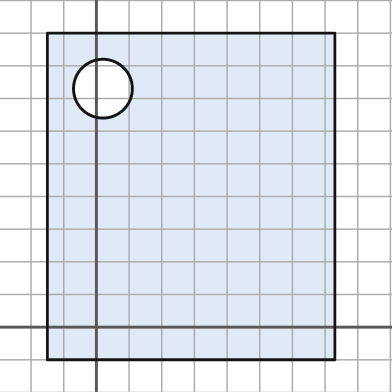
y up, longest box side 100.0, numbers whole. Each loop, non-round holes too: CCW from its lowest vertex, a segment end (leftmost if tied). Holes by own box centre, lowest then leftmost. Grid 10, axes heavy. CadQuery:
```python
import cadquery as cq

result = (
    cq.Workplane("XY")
    .moveTo(-15.0, -10.0)
    .lineTo(73.0, -10.0)
    .lineTo(73.0, 90.0)
    .lineTo(-15.0, 90.0)
    .close()
    .moveTo(2.0, 73.0)
    .circle(9.0)
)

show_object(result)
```